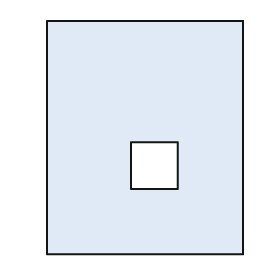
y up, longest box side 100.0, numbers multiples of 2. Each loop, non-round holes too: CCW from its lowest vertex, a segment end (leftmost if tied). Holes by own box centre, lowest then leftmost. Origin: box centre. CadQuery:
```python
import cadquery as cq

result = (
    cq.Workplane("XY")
    .moveTo(-42.0, -50.0)
    .lineTo(42.0, -50.0)
    .lineTo(42.0, 50.0)
    .lineTo(-42.0, 50.0)
    .close()
    .moveTo(-6.0, -22.0)
    .lineTo(14.0, -22.0)
    .lineTo(14.0, -2.0)
    .lineTo(-6.0, -2.0)
    .close()
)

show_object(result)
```